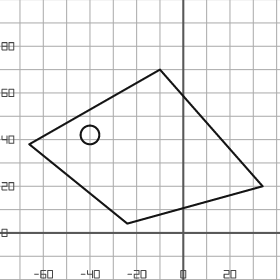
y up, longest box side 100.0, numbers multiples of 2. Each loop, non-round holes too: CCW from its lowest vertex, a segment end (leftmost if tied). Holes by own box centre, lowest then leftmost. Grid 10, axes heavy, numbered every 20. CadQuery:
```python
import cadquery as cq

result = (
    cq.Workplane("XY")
    .moveTo(-24.0, 4.0)
    .lineTo(34.0, 20.0)
    .lineTo(-10.0, 70.0)
    .lineTo(-66.0, 38.0)
    .close()
    .moveTo(-40.0, 42.0)
    .circle(4.0)
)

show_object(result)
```